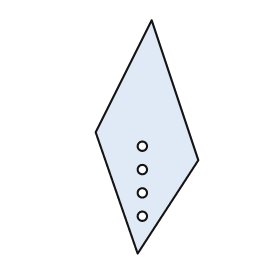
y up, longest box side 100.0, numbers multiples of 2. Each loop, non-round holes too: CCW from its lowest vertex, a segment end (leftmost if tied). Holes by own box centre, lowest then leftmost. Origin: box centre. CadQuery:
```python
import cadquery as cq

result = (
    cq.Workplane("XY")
    .moveTo(-4.0, -50.0)
    .lineTo(22.0, -10.0)
    .lineTo(2.0, 50.0)
    .lineTo(-22.0, 2.0)
    .close()
    .moveTo(-2.0, -34.0)
    .circle(2.0)
    .moveTo(-2.0, -24.0)
    .circle(2.0)
    .moveTo(-2.0, -14.0)
    .circle(2.0)
    .moveTo(-2.0, -4.0)
    .circle(2.0)
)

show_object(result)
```